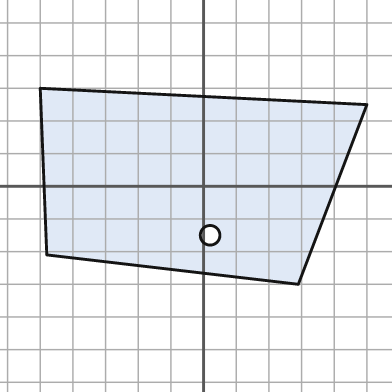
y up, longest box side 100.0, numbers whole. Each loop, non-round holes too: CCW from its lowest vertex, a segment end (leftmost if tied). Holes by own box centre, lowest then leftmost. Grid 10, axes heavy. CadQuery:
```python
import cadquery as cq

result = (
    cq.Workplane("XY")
    .moveTo(29.0, -30.0)
    .lineTo(50.0, 25.0)
    .lineTo(-50.0, 30.0)
    .lineTo(-48.0, -21.0)
    .close()
    .moveTo(2.0, -15.0)
    .circle(3.0)
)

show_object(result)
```